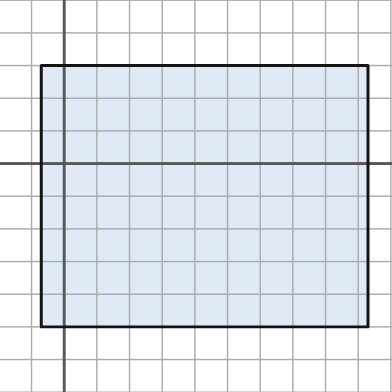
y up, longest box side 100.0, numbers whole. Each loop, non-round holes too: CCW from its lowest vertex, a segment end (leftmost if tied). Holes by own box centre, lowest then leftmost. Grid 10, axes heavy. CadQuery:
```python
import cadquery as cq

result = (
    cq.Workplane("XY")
    .moveTo(-7.0, -50.0)
    .lineTo(93.0, -50.0)
    .lineTo(93.0, 30.0)
    .lineTo(-7.0, 30.0)
    .close()
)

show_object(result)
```